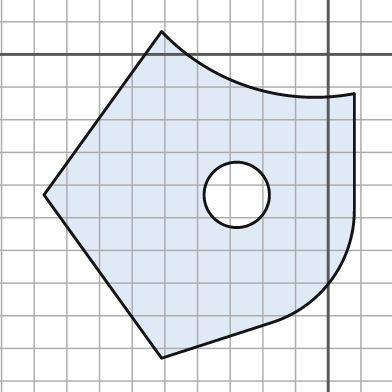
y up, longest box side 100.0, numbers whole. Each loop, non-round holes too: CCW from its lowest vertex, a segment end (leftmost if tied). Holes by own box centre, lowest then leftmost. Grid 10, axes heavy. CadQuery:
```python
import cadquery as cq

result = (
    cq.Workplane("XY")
    .moveTo(-51.0, -93.0)
    .lineTo(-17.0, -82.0)
    .threePointArc((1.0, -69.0), (8.0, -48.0))
    .lineTo(8.0, -12.0)
    .threePointArc((-24.0, -10.0), (-51.0, 7.0))
    .lineTo(-87.0, -43.0)
    .close()
    .moveTo(-28.0, -43.0)
    .circle(10.0)
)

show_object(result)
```